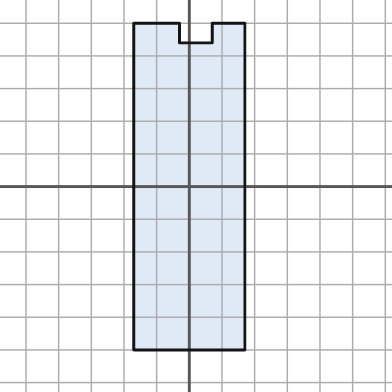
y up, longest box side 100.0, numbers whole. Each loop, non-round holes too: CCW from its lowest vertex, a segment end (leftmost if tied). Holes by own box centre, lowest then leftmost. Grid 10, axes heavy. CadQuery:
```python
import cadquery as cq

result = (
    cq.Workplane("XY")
    .moveTo(-17.0, -50.0)
    .lineTo(17.0, -50.0)
    .lineTo(17.0, 50.0)
    .lineTo(7.0, 50.0)
    .lineTo(7.0, 44.0)
    .lineTo(-3.0, 44.0)
    .lineTo(-3.0, 50.0)
    .lineTo(-17.0, 50.0)
    .close()
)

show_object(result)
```